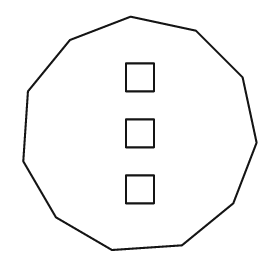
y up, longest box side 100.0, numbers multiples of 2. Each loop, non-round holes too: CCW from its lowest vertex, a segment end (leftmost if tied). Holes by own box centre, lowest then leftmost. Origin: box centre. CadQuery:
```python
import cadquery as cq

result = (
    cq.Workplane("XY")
    .moveTo(-12.0, -50.0)
    .lineTo(18.0, -48.0)
    .lineTo(40.0, -30.0)
    .lineTo(50.0, -4.0)
    .lineTo(44.0, 24.0)
    .lineTo(24.0, 44.0)
    .lineTo(-4.0, 50.0)
    .lineTo(-30.0, 40.0)
    .lineTo(-48.0, 18.0)
    .lineTo(-50.0, -12.0)
    .lineTo(-36.0, -36.0)
    .close()
    .moveTo(-6.0, -30.0)
    .lineTo(6.0, -30.0)
    .lineTo(6.0, -18.0)
    .lineTo(-6.0, -18.0)
    .close()
    .moveTo(-6.0, -6.0)
    .lineTo(6.0, -6.0)
    .lineTo(6.0, 6.0)
    .lineTo(-6.0, 6.0)
    .close()
    .moveTo(-6.0, 18.0)
    .lineTo(6.0, 18.0)
    .lineTo(6.0, 30.0)
    .lineTo(-6.0, 30.0)
    .close()
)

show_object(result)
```